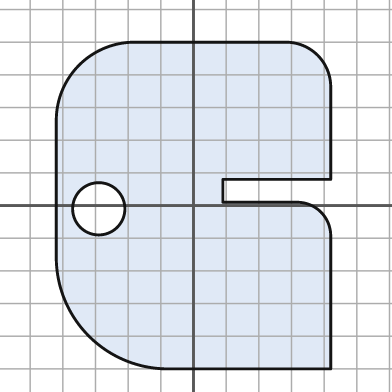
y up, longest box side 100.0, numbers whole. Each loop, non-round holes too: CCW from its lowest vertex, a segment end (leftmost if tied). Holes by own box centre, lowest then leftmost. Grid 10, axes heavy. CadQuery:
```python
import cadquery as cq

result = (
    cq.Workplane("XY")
    .moveTo(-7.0, -50.0)
    .lineTo(42.0, -50.0)
    .lineTo(42.0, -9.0)
    .threePointArc((39.0, -2.0), (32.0, 1.0))
    .lineTo(9.0, 1.0)
    .lineTo(9.0, 8.0)
    .lineTo(42.0, 8.0)
    .lineTo(42.0, 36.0)
    .threePointArc((38.0, 46.0), (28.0, 50.0))
    .lineTo(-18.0, 50.0)
    .threePointArc((-35.0, 43.0), (-42.0, 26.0))
    .lineTo(-42.0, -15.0)
    .threePointArc((-32.0, -40.0), (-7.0, -50.0))
    .close()
    .moveTo(-29.0, -1.0)
    .circle(8.0)
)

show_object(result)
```